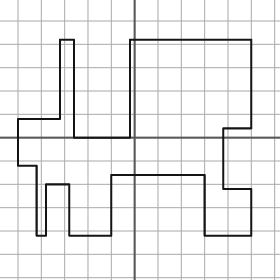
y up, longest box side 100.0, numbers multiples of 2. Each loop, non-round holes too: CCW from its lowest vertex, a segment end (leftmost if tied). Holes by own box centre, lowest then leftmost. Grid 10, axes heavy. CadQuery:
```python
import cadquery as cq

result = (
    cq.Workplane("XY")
    .moveTo(-42.0, -42.0)
    .lineTo(-38.0, -42.0)
    .lineTo(-38.0, -20.0)
    .lineTo(-28.0, -20.0)
    .lineTo(-28.0, -42.0)
    .lineTo(-10.0, -42.0)
    .lineTo(-10.0, -16.0)
    .lineTo(30.0, -16.0)
    .lineTo(30.0, -42.0)
    .lineTo(50.0, -42.0)
    .lineTo(50.0, -22.0)
    .lineTo(38.0, -22.0)
    .lineTo(38.0, 4.0)
    .lineTo(50.0, 4.0)
    .lineTo(50.0, 42.0)
    .lineTo(-2.0, 42.0)
    .lineTo(-2.0, 0.0)
    .lineTo(-26.0, 0.0)
    .lineTo(-26.0, 42.0)
    .lineTo(-32.0, 42.0)
    .lineTo(-32.0, 8.0)
    .lineTo(-50.0, 8.0)
    .lineTo(-50.0, -12.0)
    .lineTo(-42.0, -12.0)
    .close()
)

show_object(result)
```